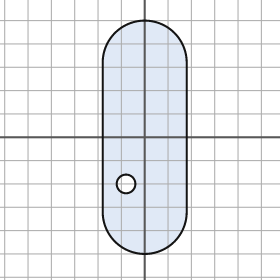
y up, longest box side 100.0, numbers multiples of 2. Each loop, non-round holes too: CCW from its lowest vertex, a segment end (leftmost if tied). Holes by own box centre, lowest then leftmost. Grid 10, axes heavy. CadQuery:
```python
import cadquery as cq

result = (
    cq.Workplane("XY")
    .moveTo(-18.0, -32.0)
    .threePointArc((0.0, -50.0), (18.0, -32.0))
    .lineTo(18.0, 32.0)
    .threePointArc((0.0, 50.0), (-18.0, 32.0))
    .close()
    .moveTo(-8.0, -20.0)
    .circle(4.0)
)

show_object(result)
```